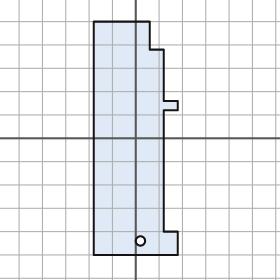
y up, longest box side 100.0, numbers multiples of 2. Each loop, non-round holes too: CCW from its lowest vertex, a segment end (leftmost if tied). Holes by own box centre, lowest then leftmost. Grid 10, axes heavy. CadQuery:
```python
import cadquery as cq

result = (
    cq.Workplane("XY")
    .moveTo(-18.0, -50.0)
    .lineTo(18.0, -50.0)
    .lineTo(18.0, -40.0)
    .lineTo(12.0, -40.0)
    .lineTo(12.0, 12.0)
    .lineTo(18.0, 12.0)
    .lineTo(18.0, 16.0)
    .lineTo(12.0, 16.0)
    .lineTo(12.0, 38.0)
    .lineTo(6.0, 38.0)
    .lineTo(6.0, 50.0)
    .lineTo(-18.0, 50.0)
    .close()
    .moveTo(2.0, -44.0)
    .circle(2.0)
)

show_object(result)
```